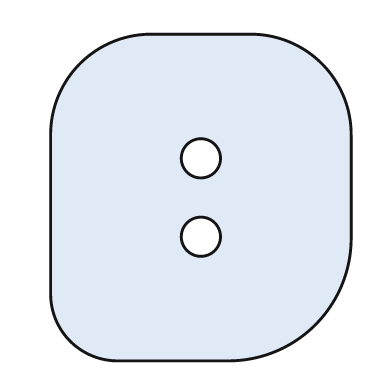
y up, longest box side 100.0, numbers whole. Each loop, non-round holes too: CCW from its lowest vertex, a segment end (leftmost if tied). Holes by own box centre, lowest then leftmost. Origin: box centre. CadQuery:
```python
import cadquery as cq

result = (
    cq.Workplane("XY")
    .moveTo(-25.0, -50.0)
    .lineTo(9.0, -50.0)
    .threePointArc((35.0, -39.0), (46.0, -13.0))
    .lineTo(46.0, 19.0)
    .threePointArc((37.0, 41.0), (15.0, 50.0))
    .lineTo(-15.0, 50.0)
    .threePointArc((-37.0, 41.0), (-46.0, 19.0))
    .lineTo(-46.0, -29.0)
    .threePointArc((-40.0, -44.0), (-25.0, -50.0))
    .close()
    .moveTo(0.0, -12.0)
    .circle(6.0)
    .moveTo(0.0, 12.0)
    .circle(6.0)
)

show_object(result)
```